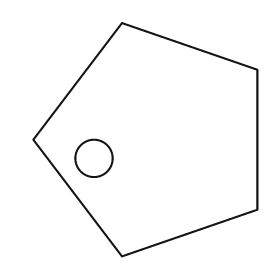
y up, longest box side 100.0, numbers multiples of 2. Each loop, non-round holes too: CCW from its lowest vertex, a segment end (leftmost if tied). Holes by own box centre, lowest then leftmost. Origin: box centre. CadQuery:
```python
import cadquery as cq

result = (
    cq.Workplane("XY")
    .moveTo(-10.0, -50.0)
    .lineTo(48.0, -30.0)
    .lineTo(48.0, 30.0)
    .lineTo(-10.0, 50.0)
    .lineTo(-48.0, 0.0)
    .close()
    .moveTo(-22.0, -8.0)
    .circle(8.0)
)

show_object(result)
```